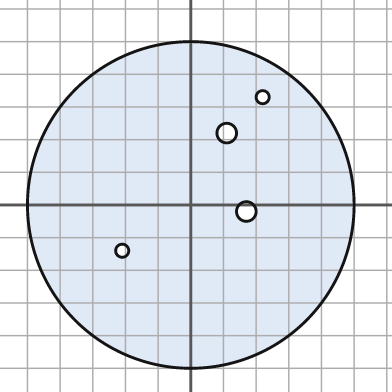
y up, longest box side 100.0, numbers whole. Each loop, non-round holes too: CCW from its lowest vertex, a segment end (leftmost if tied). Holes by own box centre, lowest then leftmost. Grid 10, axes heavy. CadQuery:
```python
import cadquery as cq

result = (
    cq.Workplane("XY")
    .moveTo(0.0, 0.0)
    .circle(50.0)
    .moveTo(-21.0, -14.0)
    .circle(2.0)
    .moveTo(17.0, -2.0)
    .circle(3.0)
    .moveTo(11.0, 22.0)
    .circle(3.0)
    .moveTo(22.0, 33.0)
    .circle(2.0)
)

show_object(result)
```